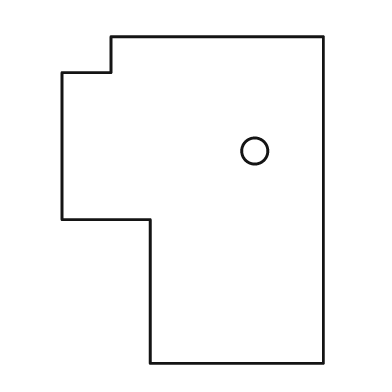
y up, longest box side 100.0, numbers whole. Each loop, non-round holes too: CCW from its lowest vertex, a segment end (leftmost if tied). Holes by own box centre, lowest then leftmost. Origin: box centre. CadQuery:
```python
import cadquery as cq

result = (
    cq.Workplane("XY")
    .moveTo(-13.0, -50.0)
    .lineTo(40.0, -50.0)
    .lineTo(40.0, 50.0)
    .lineTo(-25.0, 50.0)
    .lineTo(-25.0, 39.0)
    .lineTo(-40.0, 39.0)
    .lineTo(-40.0, -6.0)
    .lineTo(-13.0, -6.0)
    .close()
    .moveTo(19.0, 15.0)
    .circle(4.0)
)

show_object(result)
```